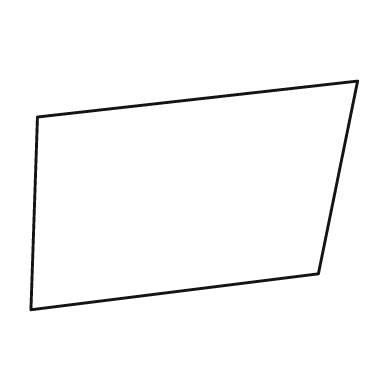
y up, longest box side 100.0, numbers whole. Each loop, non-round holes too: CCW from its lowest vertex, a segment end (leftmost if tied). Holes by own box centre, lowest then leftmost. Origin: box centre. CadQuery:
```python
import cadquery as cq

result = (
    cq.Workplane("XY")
    .moveTo(-50.0, -35.0)
    .lineTo(38.0, -24.0)
    .lineTo(50.0, 35.0)
    .lineTo(-48.0, 24.0)
    .close()
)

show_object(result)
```